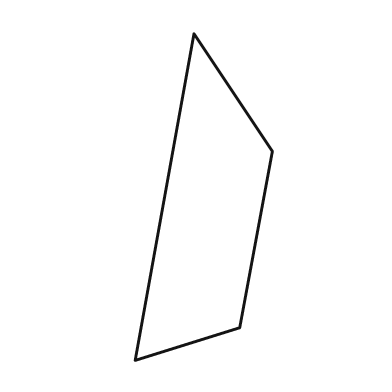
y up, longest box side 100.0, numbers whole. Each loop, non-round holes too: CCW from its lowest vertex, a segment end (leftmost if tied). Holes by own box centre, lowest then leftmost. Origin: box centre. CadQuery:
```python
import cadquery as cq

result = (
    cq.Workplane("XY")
    .moveTo(-21.0, -50.0)
    .lineTo(11.0, -40.0)
    .lineTo(21.0, 14.0)
    .lineTo(-3.0, 50.0)
    .close()
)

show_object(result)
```